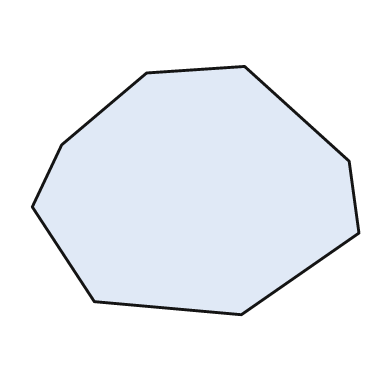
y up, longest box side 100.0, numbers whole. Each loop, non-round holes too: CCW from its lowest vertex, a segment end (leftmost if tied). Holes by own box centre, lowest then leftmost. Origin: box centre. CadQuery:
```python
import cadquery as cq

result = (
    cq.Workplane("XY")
    .moveTo(14.0, -38.0)
    .lineTo(50.0, -13.0)
    .lineTo(47.0, 9.0)
    .lineTo(15.0, 38.0)
    .lineTo(-15.0, 36.0)
    .lineTo(-41.0, 14.0)
    .lineTo(-50.0, -5.0)
    .lineTo(-31.0, -34.0)
    .close()
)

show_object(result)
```